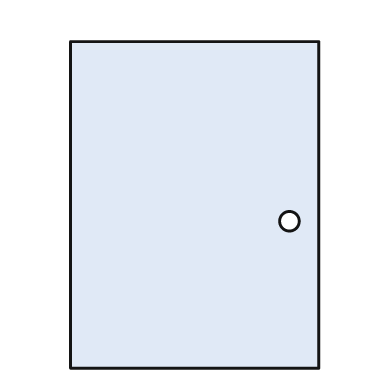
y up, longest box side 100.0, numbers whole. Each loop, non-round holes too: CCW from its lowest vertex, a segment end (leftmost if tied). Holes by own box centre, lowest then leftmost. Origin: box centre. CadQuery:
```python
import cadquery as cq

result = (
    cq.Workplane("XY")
    .moveTo(-38.0, -50.0)
    .lineTo(38.0, -50.0)
    .lineTo(38.0, 50.0)
    .lineTo(-38.0, 50.0)
    .close()
    .moveTo(29.0, -5.0)
    .circle(3.0)
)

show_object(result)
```